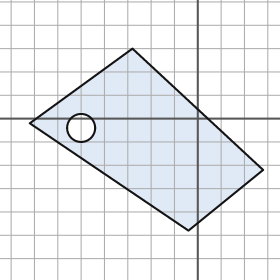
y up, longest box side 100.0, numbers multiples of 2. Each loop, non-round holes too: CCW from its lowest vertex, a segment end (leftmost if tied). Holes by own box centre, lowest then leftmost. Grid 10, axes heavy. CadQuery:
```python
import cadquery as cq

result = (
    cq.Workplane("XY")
    .moveTo(-4.0, -48.0)
    .lineTo(28.0, -22.0)
    .lineTo(-28.0, 30.0)
    .lineTo(-72.0, -2.0)
    .close()
    .moveTo(-50.0, -4.0)
    .circle(6.0)
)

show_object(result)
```